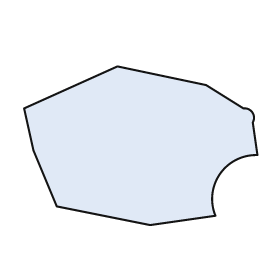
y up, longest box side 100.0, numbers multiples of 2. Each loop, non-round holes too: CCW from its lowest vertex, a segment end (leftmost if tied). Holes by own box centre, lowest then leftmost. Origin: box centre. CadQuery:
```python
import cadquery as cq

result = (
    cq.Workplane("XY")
    .moveTo(4.0, -34.0)
    .lineTo(32.0, -30.0)
    .threePointArc((34.0, -12.0), (50.0, -4.0))
    .lineTo(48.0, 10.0)
    .threePointArc((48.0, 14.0), (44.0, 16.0))
    .lineTo(28.0, 26.0)
    .lineTo(-10.0, 34.0)
    .lineTo(-50.0, 16.0)
    .lineTo(-46.0, -2.0)
    .lineTo(-36.0, -26.0)
    .close()
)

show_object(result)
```